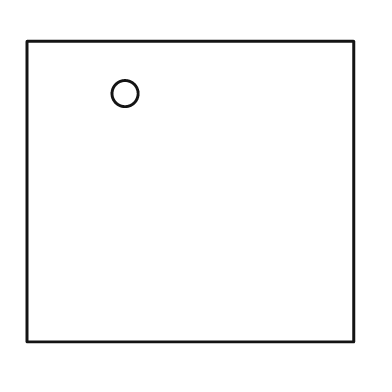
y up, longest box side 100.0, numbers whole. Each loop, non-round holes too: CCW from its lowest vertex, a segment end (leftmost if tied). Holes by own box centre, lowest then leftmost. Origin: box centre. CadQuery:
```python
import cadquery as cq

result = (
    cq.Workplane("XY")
    .moveTo(-50.0, -46.0)
    .lineTo(50.0, -46.0)
    .lineTo(50.0, 46.0)
    .lineTo(-50.0, 46.0)
    .close()
    .moveTo(-20.0, 30.0)
    .circle(4.0)
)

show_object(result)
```